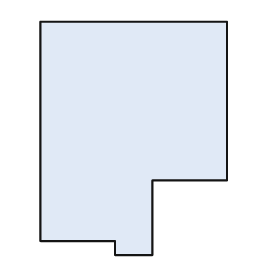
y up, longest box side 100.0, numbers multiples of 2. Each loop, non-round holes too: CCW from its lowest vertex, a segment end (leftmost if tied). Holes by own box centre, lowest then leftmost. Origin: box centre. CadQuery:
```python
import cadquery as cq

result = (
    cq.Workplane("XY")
    .moveTo(-8.0, -50.0)
    .lineTo(8.0, -50.0)
    .lineTo(8.0, -18.0)
    .lineTo(40.0, -18.0)
    .lineTo(40.0, 50.0)
    .lineTo(-40.0, 50.0)
    .lineTo(-40.0, -44.0)
    .lineTo(-8.0, -44.0)
    .close()
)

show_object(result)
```